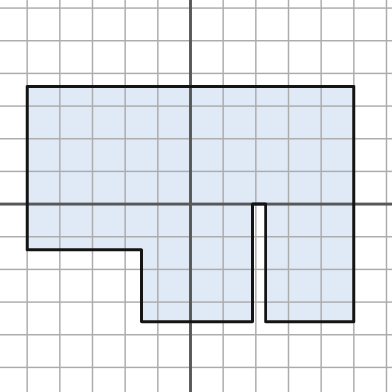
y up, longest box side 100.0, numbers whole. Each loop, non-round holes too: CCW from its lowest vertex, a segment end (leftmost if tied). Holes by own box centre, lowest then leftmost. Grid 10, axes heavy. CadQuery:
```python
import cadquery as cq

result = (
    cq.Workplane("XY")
    .moveTo(-15.0, -36.0)
    .lineTo(19.0, -36.0)
    .lineTo(19.0, 0.0)
    .lineTo(23.0, 0.0)
    .lineTo(23.0, -36.0)
    .lineTo(50.0, -36.0)
    .lineTo(50.0, 36.0)
    .lineTo(-50.0, 36.0)
    .lineTo(-50.0, -14.0)
    .lineTo(-15.0, -14.0)
    .close()
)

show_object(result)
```